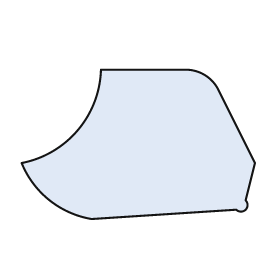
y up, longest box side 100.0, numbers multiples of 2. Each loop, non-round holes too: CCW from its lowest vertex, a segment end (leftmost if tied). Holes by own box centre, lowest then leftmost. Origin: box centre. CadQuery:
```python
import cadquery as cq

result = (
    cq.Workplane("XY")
    .moveTo(-20.0, -32.0)
    .lineTo(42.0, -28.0)
    .threePointArc((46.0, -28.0), (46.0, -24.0))
    .lineTo(50.0, -8.0)
    .lineTo(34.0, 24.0)
    .threePointArc((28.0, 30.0), (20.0, 32.0))
    .lineTo(-16.0, 32.0)
    .threePointArc((-26.0, 6.0), (-50.0, -8.0))
    .threePointArc((-38.0, -24.0), (-20.0, -32.0))
    .close()
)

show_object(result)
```